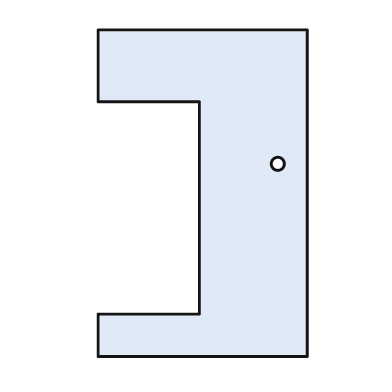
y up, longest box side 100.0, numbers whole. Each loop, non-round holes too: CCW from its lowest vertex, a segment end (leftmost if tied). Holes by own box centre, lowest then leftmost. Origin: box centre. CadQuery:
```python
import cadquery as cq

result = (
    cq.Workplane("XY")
    .moveTo(-32.0, -50.0)
    .lineTo(32.0, -50.0)
    .lineTo(32.0, 50.0)
    .lineTo(-32.0, 50.0)
    .lineTo(-32.0, 28.0)
    .lineTo(-1.0, 28.0)
    .lineTo(-1.0, -37.0)
    .lineTo(-32.0, -37.0)
    .close()
    .moveTo(23.0, 9.0)
    .circle(2.0)
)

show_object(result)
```